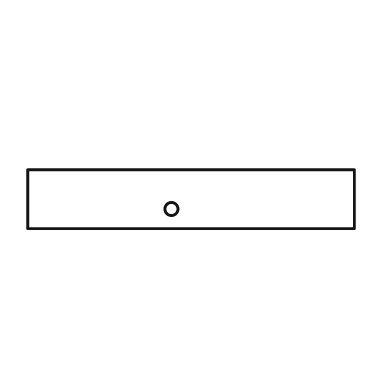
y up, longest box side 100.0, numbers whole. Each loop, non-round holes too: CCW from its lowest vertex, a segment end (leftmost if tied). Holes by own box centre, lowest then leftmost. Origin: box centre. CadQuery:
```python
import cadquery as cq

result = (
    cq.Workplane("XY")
    .moveTo(-50.0, -9.0)
    .lineTo(50.0, -9.0)
    .lineTo(50.0, 9.0)
    .lineTo(-50.0, 9.0)
    .close()
    .moveTo(-6.0, -3.0)
    .circle(2.0)
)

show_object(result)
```